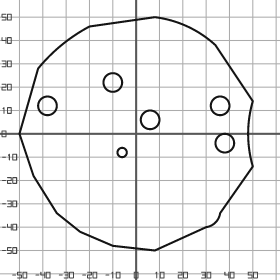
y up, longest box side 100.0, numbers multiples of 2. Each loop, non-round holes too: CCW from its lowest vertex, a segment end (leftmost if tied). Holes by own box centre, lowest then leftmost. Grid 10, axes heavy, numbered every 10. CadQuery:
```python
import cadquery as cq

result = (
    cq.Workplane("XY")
    .moveTo(8.0, -50.0)
    .lineTo(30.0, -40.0)
    .threePointArc((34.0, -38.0), (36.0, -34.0))
    .lineTo(50.0, -14.0)
    .threePointArc((48.0, 0.0), (50.0, 14.0))
    .lineTo(34.0, 38.0)
    .threePointArc((22.0, 46.0), (8.0, 50.0))
    .lineTo(-20.0, 46.0)
    .threePointArc((-32.0, 38.0), (-42.0, 28.0))
    .lineTo(-50.0, 0.0)
    .lineTo(-44.0, -18.0)
    .lineTo(-34.0, -34.0)
    .lineTo(-24.0, -42.0)
    .lineTo(-10.0, -48.0)
    .close()
    .moveTo(-6.0, -8.0)
    .circle(2.0)
    .moveTo(38.0, -4.0)
    .circle(4.0)
    .moveTo(6.0, 6.0)
    .circle(4.0)
    .moveTo(-38.0, 12.0)
    .circle(4.0)
    .moveTo(36.0, 12.0)
    .circle(4.0)
    .moveTo(-10.0, 22.0)
    .circle(4.0)
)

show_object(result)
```